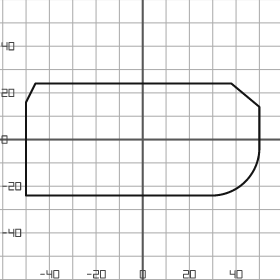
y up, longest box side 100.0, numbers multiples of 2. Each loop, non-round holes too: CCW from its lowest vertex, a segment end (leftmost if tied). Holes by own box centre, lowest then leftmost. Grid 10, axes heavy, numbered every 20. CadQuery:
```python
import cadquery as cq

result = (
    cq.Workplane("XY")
    .moveTo(-50.0, -24.0)
    .lineTo(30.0, -24.0)
    .threePointArc((44.0, -18.0), (50.0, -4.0))
    .lineTo(50.0, 14.0)
    .lineTo(38.0, 24.0)
    .lineTo(-46.0, 24.0)
    .lineTo(-50.0, 16.0)
    .close()
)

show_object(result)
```